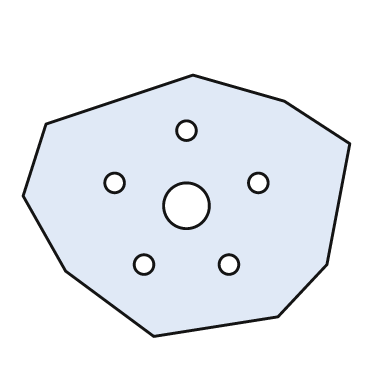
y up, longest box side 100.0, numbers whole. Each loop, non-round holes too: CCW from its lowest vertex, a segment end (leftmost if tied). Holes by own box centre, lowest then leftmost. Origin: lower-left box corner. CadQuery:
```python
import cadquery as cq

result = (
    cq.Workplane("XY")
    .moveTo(40.0, 0.0)
    .lineTo(78.0, 6.0)
    .lineTo(93.0, 22.0)
    .lineTo(100.0, 59.0)
    .lineTo(80.0, 72.0)
    .lineTo(52.0, 80.0)
    .lineTo(7.0, 65.0)
    .lineTo(0.0, 43.0)
    .lineTo(13.0, 20.0)
    .close()
    .moveTo(37.0, 22.0)
    .circle(3.0)
    .moveTo(63.0, 22.0)
    .circle(3.0)
    .moveTo(50.0, 40.0)
    .circle(7.0)
    .moveTo(28.0, 47.0)
    .circle(3.0)
    .moveTo(72.0, 47.0)
    .circle(3.0)
    .moveTo(50.0, 63.0)
    .circle(3.0)
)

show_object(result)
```